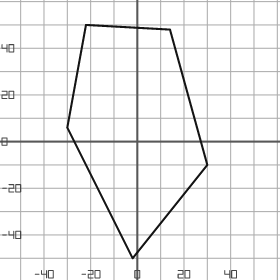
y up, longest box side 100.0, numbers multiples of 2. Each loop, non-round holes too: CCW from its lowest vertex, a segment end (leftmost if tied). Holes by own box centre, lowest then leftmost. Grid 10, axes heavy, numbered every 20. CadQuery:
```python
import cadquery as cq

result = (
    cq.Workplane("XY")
    .moveTo(-2.0, -50.0)
    .lineTo(30.0, -10.0)
    .lineTo(14.0, 48.0)
    .lineTo(-22.0, 50.0)
    .lineTo(-30.0, 6.0)
    .close()
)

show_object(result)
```